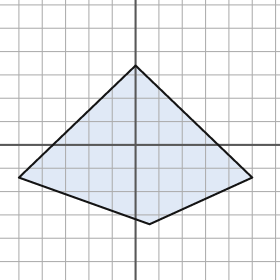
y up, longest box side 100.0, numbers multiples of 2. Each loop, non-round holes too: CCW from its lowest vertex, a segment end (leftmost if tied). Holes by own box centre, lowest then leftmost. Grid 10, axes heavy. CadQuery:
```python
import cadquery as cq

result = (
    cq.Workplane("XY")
    .moveTo(6.0, -34.0)
    .lineTo(50.0, -14.0)
    .lineTo(0.0, 34.0)
    .lineTo(-50.0, -14.0)
    .close()
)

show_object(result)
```